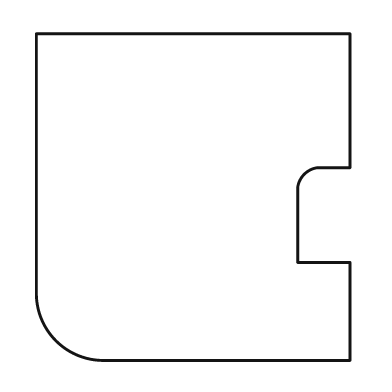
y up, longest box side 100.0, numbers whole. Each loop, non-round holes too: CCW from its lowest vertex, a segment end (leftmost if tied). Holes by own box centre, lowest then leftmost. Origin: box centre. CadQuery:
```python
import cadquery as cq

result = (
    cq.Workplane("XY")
    .moveTo(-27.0, -50.0)
    .lineTo(48.0, -50.0)
    .lineTo(48.0, -20.0)
    .lineTo(32.0, -20.0)
    .lineTo(32.0, 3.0)
    .threePointArc((34.0, 7.0), (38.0, 9.0))
    .lineTo(48.0, 9.0)
    .lineTo(48.0, 50.0)
    .lineTo(-48.0, 50.0)
    .lineTo(-48.0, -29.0)
    .threePointArc((-42.0, -44.0), (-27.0, -50.0))
    .close()
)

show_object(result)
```